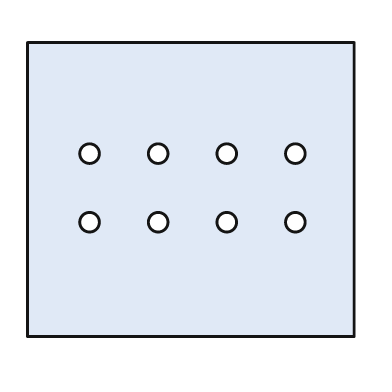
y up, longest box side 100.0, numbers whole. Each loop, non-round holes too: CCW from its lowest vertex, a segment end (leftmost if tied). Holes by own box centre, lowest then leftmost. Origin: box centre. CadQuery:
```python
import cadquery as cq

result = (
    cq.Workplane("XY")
    .moveTo(-50.0, -45.0)
    .lineTo(50.0, -45.0)
    .lineTo(50.0, 45.0)
    .lineTo(-50.0, 45.0)
    .close()
    .moveTo(-31.0, -10.0)
    .circle(3.0)
    .moveTo(-10.0, -10.0)
    .circle(3.0)
    .moveTo(11.0, -10.0)
    .circle(3.0)
    .moveTo(32.0, -10.0)
    .circle(3.0)
    .moveTo(-31.0, 11.0)
    .circle(3.0)
    .moveTo(-10.0, 11.0)
    .circle(3.0)
    .moveTo(11.0, 11.0)
    .circle(3.0)
    .moveTo(32.0, 11.0)
    .circle(3.0)
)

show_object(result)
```